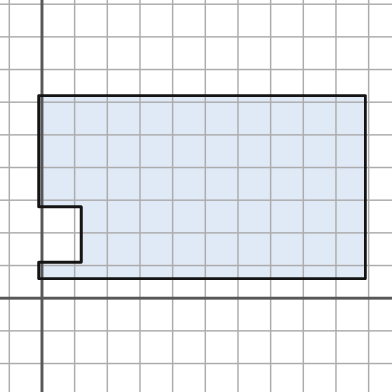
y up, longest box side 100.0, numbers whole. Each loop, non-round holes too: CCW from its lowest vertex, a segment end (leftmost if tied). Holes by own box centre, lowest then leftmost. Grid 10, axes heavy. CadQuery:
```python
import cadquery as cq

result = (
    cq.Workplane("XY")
    .moveTo(-1.0, 6.0)
    .lineTo(99.0, 6.0)
    .lineTo(99.0, 62.0)
    .lineTo(-1.0, 62.0)
    .lineTo(-1.0, 28.0)
    .lineTo(12.0, 28.0)
    .lineTo(12.0, 11.0)
    .lineTo(-1.0, 11.0)
    .close()
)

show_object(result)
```